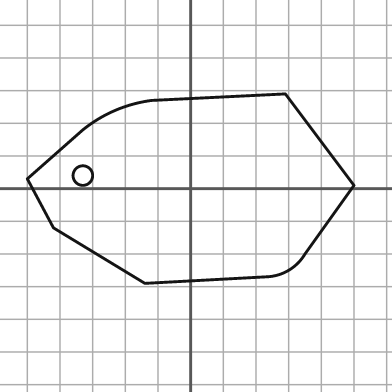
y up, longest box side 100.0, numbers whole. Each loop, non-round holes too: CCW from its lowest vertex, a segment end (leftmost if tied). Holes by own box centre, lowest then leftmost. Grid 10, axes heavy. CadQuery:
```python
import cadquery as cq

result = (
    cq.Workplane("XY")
    .moveTo(-14.0, -29.0)
    .lineTo(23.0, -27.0)
    .threePointArc((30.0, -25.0), (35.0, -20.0))
    .lineTo(50.0, 1.0)
    .lineTo(29.0, 29.0)
    .lineTo(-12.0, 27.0)
    .threePointArc((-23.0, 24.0), (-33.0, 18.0))
    .lineTo(-50.0, 3.0)
    .lineTo(-42.0, -12.0)
    .close()
    .moveTo(-33.0, 4.0)
    .circle(3.0)
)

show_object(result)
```